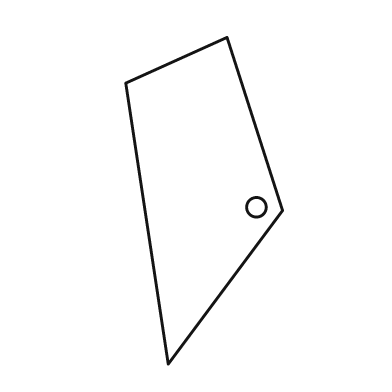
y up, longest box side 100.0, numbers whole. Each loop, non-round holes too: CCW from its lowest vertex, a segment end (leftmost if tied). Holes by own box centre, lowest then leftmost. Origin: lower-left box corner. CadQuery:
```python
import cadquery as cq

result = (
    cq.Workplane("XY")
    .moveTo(13.0, 0.0)
    .lineTo(48.0, 47.0)
    .lineTo(31.0, 100.0)
    .lineTo(0.0, 86.0)
    .close()
    .moveTo(40.0, 48.0)
    .circle(3.0)
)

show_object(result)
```